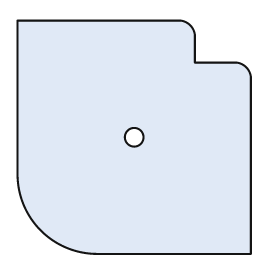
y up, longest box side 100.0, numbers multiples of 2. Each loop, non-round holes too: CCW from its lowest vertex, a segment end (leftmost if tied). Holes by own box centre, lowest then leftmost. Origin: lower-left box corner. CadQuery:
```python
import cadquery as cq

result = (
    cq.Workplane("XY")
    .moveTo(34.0, 0.0)
    .lineTo(100.0, 0.0)
    .lineTo(100.0, 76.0)
    .threePointArc((98.0, 80.0), (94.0, 82.0))
    .lineTo(76.0, 82.0)
    .lineTo(76.0, 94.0)
    .threePointArc((74.0, 98.0), (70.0, 100.0))
    .lineTo(0.0, 100.0)
    .lineTo(0.0, 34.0)
    .threePointArc((10.0, 10.0), (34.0, 0.0))
    .close()
    .moveTo(50.0, 50.0)
    .circle(4.0)
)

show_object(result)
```